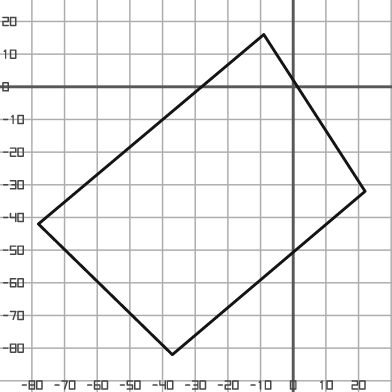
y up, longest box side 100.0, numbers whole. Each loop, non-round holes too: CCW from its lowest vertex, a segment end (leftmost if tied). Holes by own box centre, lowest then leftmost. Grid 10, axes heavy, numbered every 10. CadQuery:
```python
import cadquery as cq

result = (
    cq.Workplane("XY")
    .moveTo(-37.0, -82.0)
    .lineTo(22.0, -32.0)
    .lineTo(-9.0, 16.0)
    .lineTo(-78.0, -42.0)
    .close()
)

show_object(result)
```